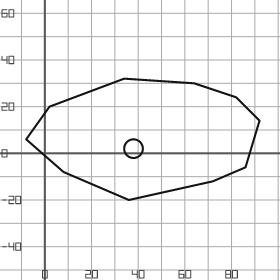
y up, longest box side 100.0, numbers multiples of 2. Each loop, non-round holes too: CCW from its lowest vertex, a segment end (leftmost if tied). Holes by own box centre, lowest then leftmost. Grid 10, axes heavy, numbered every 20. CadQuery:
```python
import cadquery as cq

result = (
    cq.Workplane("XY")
    .moveTo(36.0, -20.0)
    .lineTo(72.0, -12.0)
    .lineTo(86.0, -6.0)
    .lineTo(92.0, 14.0)
    .lineTo(82.0, 24.0)
    .lineTo(64.0, 30.0)
    .lineTo(34.0, 32.0)
    .lineTo(2.0, 20.0)
    .lineTo(-8.0, 6.0)
    .lineTo(8.0, -8.0)
    .close()
    .moveTo(38.0, 2.0)
    .circle(4.0)
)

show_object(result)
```